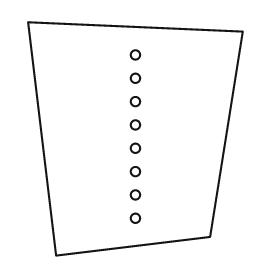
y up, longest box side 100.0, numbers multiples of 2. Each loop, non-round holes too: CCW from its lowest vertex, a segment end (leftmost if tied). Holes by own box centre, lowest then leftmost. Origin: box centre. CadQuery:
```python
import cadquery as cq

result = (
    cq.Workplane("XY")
    .moveTo(-34.0, -50.0)
    .lineTo(32.0, -42.0)
    .lineTo(46.0, 46.0)
    .lineTo(-46.0, 50.0)
    .close()
    .moveTo(0.0, -34.0)
    .circle(2.0)
    .moveTo(0.0, -24.0)
    .circle(2.0)
    .moveTo(0.0, -14.0)
    .circle(2.0)
    .moveTo(0.0, -4.0)
    .circle(2.0)
    .moveTo(0.0, 6.0)
    .circle(2.0)
    .moveTo(0.0, 16.0)
    .circle(2.0)
    .moveTo(0.0, 26.0)
    .circle(2.0)
    .moveTo(0.0, 36.0)
    .circle(2.0)
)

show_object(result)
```